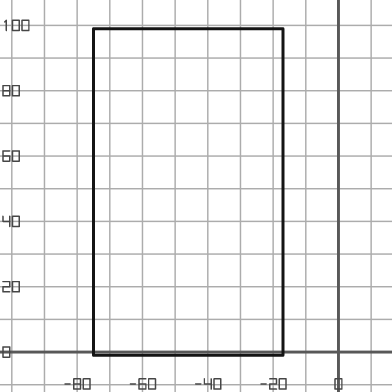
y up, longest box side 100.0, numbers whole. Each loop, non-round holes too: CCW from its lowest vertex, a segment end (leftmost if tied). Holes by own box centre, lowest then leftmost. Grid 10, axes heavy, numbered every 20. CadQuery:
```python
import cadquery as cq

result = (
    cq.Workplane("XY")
    .moveTo(-75.0, -1.0)
    .lineTo(-17.0, -1.0)
    .lineTo(-17.0, 99.0)
    .lineTo(-75.0, 99.0)
    .close()
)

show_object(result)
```